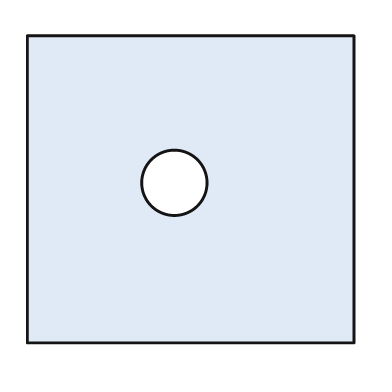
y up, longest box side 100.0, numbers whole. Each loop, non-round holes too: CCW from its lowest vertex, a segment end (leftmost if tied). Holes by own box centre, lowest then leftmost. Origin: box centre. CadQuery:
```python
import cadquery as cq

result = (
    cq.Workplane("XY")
    .moveTo(-50.0, -47.0)
    .lineTo(50.0, -47.0)
    .lineTo(50.0, 47.0)
    .lineTo(-50.0, 47.0)
    .close()
    .moveTo(-5.0, 2.0)
    .circle(10.0)
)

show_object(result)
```